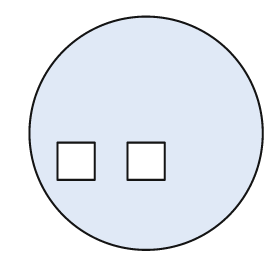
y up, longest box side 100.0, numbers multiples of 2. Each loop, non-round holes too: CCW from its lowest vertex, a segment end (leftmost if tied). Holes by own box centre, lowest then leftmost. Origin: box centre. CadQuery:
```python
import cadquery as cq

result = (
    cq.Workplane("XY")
    .moveTo(0.0, 0.0)
    .circle(50.0)
    .moveTo(-38.0, -20.0)
    .lineTo(-22.0, -20.0)
    .lineTo(-22.0, -4.0)
    .lineTo(-38.0, -4.0)
    .close()
    .moveTo(-8.0, -20.0)
    .lineTo(8.0, -20.0)
    .lineTo(8.0, -4.0)
    .lineTo(-8.0, -4.0)
    .close()
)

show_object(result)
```